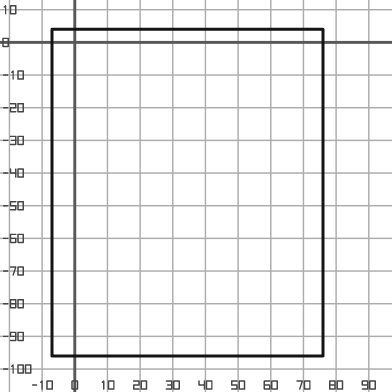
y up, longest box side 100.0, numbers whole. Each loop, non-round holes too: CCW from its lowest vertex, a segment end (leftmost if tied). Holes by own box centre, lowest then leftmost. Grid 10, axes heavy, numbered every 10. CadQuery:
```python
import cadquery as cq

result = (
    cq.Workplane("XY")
    .moveTo(-7.0, -96.0)
    .lineTo(76.0, -96.0)
    .lineTo(76.0, 4.0)
    .lineTo(-7.0, 4.0)
    .close()
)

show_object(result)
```